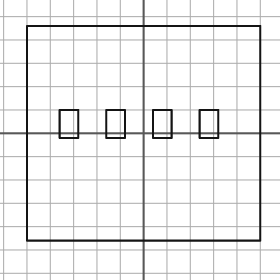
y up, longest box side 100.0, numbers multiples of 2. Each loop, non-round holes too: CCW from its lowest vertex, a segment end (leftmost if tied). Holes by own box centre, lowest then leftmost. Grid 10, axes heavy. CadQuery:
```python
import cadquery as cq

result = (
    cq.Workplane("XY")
    .moveTo(-50.0, -46.0)
    .lineTo(50.0, -46.0)
    .lineTo(50.0, 46.0)
    .lineTo(-50.0, 46.0)
    .close()
    .moveTo(-36.0, -2.0)
    .lineTo(-28.0, -2.0)
    .lineTo(-28.0, 10.0)
    .lineTo(-36.0, 10.0)
    .close()
    .moveTo(-16.0, -2.0)
    .lineTo(-8.0, -2.0)
    .lineTo(-8.0, 10.0)
    .lineTo(-16.0, 10.0)
    .close()
    .moveTo(4.0, -2.0)
    .lineTo(12.0, -2.0)
    .lineTo(12.0, 10.0)
    .lineTo(4.0, 10.0)
    .close()
    .moveTo(24.0, -2.0)
    .lineTo(32.0, -2.0)
    .lineTo(32.0, 10.0)
    .lineTo(24.0, 10.0)
    .close()
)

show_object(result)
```